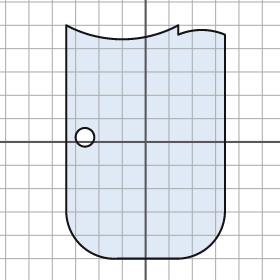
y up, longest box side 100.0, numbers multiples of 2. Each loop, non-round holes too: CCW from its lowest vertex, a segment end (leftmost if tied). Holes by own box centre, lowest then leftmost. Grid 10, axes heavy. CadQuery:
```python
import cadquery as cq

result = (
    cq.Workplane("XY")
    .moveTo(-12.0, -50.0)
    .lineTo(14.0, -50.0)
    .threePointArc((28.0, -44.0), (34.0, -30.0))
    .lineTo(34.0, 46.0)
    .threePointArc((24.0, 48.0), (14.0, 46.0))
    .lineTo(14.0, 50.0)
    .threePointArc((-10.0, 44.0), (-34.0, 50.0))
    .lineTo(-34.0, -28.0)
    .threePointArc((-28.0, -44.0), (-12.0, -50.0))
    .close()
    .moveTo(-26.0, 2.0)
    .circle(4.0)
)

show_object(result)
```